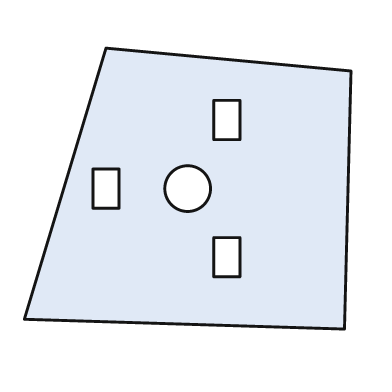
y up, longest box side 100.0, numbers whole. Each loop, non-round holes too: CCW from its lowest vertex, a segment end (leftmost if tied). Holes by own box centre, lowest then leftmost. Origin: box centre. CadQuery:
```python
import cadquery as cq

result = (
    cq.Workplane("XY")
    .moveTo(48.0, -43.0)
    .lineTo(50.0, 36.0)
    .lineTo(-25.0, 43.0)
    .lineTo(-50.0, -40.0)
    .close()
    .moveTo(8.0, -27.0)
    .lineTo(16.0, -27.0)
    .lineTo(16.0, -15.0)
    .lineTo(8.0, -15.0)
    .close()
    .moveTo(-29.0, -6.0)
    .lineTo(-21.0, -6.0)
    .lineTo(-21.0, 6.0)
    .lineTo(-29.0, 6.0)
    .close()
    .moveTo(0.0, 0.0)
    .circle(7.0)
    .moveTo(8.0, 15.0)
    .lineTo(16.0, 15.0)
    .lineTo(16.0, 27.0)
    .lineTo(8.0, 27.0)
    .close()
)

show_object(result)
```